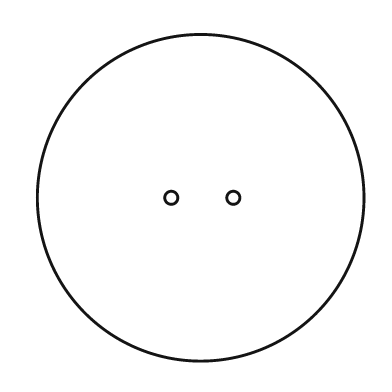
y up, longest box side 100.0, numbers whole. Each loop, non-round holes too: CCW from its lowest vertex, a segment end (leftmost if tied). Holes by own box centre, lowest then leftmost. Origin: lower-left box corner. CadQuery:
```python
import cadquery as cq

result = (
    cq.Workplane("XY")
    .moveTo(50.0, 50.0)
    .circle(50.0)
    .moveTo(41.0, 50.0)
    .circle(2.0)
    .moveTo(60.0, 50.0)
    .circle(2.0)
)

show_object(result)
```